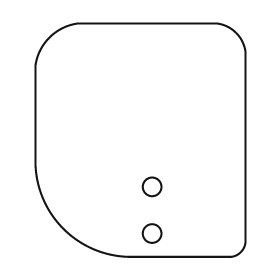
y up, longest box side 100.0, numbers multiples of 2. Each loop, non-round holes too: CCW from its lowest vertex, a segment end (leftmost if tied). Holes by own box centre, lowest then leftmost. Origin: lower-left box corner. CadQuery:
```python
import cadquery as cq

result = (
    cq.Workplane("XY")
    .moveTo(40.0, 0.0)
    .lineTo(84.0, 0.0)
    .threePointArc((88.0, 2.0), (90.0, 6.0))
    .lineTo(90.0, 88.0)
    .threePointArc((86.0, 96.0), (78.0, 100.0))
    .lineTo(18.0, 100.0)
    .threePointArc((6.0, 94.0), (0.0, 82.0))
    .lineTo(0.0, 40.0)
    .threePointArc((12.0, 12.0), (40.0, 0.0))
    .close()
    .moveTo(50.0, 10.0)
    .circle(4.0)
    .moveTo(50.0, 30.0)
    .circle(4.0)
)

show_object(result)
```